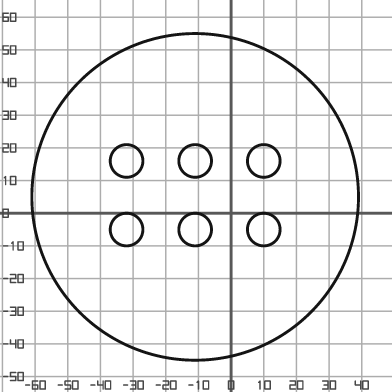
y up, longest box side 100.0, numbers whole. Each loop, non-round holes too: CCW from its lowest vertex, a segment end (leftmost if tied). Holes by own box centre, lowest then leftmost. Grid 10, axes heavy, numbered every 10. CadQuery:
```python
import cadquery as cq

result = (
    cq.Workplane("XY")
    .moveTo(-11.0, 5.0)
    .circle(50.0)
    .moveTo(-32.0, -5.0)
    .circle(5.0)
    .moveTo(-11.0, -5.0)
    .circle(5.0)
    .moveTo(10.0, -5.0)
    .circle(5.0)
    .moveTo(-32.0, 16.0)
    .circle(5.0)
    .moveTo(-11.0, 16.0)
    .circle(5.0)
    .moveTo(10.0, 16.0)
    .circle(5.0)
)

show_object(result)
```